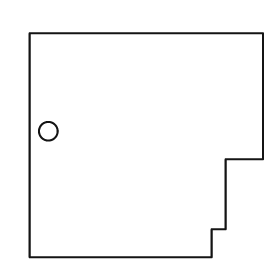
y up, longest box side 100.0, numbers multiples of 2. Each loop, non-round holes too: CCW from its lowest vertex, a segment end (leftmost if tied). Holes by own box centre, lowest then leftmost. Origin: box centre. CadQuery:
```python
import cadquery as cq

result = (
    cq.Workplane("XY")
    .moveTo(-50.0, -48.0)
    .lineTo(28.0, -48.0)
    .lineTo(28.0, -36.0)
    .lineTo(34.0, -36.0)
    .lineTo(34.0, -6.0)
    .lineTo(50.0, -6.0)
    .lineTo(50.0, 48.0)
    .lineTo(-50.0, 48.0)
    .close()
    .moveTo(-42.0, 6.0)
    .circle(4.0)
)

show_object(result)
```